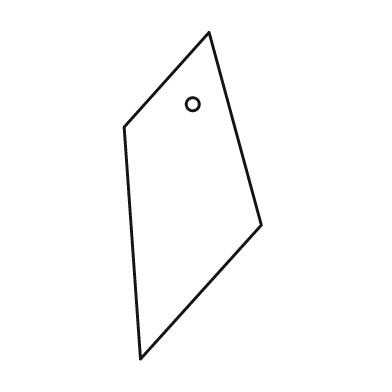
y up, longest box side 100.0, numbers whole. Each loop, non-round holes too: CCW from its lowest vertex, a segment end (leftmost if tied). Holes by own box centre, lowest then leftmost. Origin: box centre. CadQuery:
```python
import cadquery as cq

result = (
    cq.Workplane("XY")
    .moveTo(-16.0, -50.0)
    .lineTo(21.0, -9.0)
    .lineTo(5.0, 50.0)
    .lineTo(-21.0, 21.0)
    .close()
    .moveTo(0.0, 28.0)
    .circle(2.0)
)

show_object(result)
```